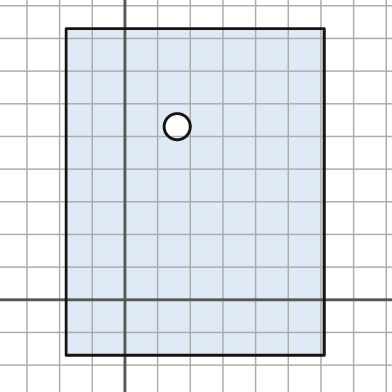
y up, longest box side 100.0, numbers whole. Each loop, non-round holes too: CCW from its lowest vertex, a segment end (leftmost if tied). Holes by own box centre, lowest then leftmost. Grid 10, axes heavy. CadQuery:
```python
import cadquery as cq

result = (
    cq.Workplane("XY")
    .moveTo(-18.0, -17.0)
    .lineTo(61.0, -17.0)
    .lineTo(61.0, 83.0)
    .lineTo(-18.0, 83.0)
    .close()
    .moveTo(16.0, 53.0)
    .circle(4.0)
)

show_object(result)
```